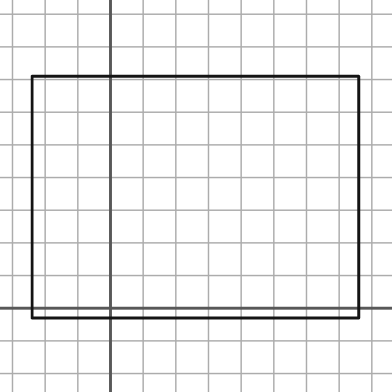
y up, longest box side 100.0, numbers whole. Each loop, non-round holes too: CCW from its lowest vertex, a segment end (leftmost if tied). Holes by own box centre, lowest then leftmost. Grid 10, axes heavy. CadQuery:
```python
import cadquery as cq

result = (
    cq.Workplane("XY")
    .moveTo(-24.0, -3.0)
    .lineTo(76.0, -3.0)
    .lineTo(76.0, 71.0)
    .lineTo(-24.0, 71.0)
    .close()
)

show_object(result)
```